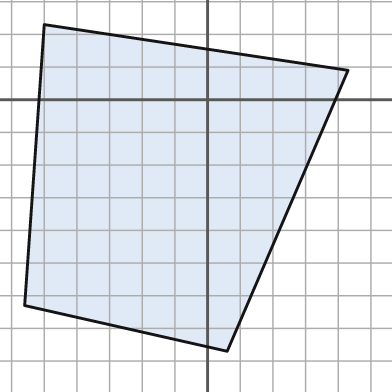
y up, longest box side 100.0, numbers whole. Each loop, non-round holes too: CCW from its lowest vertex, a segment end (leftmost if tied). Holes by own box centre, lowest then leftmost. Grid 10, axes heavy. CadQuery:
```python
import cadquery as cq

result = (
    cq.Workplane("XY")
    .moveTo(6.0, -77.0)
    .lineTo(43.0, 9.0)
    .lineTo(-50.0, 23.0)
    .lineTo(-56.0, -63.0)
    .close()
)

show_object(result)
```